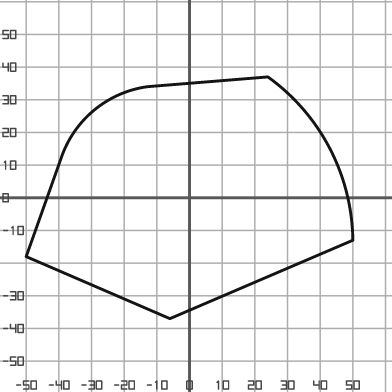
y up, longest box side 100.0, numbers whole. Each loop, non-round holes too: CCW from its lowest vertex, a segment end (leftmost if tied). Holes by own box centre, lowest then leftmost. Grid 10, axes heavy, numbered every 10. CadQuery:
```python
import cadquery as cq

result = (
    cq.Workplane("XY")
    .moveTo(-6.0, -37.0)
    .lineTo(50.0, -13.0)
    .threePointArc((43.0, 15.0), (24.0, 37.0))
    .lineTo(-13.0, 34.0)
    .threePointArc((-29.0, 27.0), (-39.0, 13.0))
    .lineTo(-50.0, -18.0)
    .close()
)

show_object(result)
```